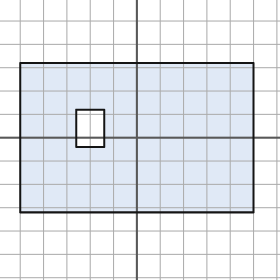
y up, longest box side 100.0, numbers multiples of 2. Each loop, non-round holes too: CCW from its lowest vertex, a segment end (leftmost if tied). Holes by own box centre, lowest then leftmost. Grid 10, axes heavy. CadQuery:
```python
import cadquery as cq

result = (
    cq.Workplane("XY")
    .moveTo(-50.0, -32.0)
    .lineTo(50.0, -32.0)
    .lineTo(50.0, 32.0)
    .lineTo(-50.0, 32.0)
    .close()
    .moveTo(-26.0, -4.0)
    .lineTo(-14.0, -4.0)
    .lineTo(-14.0, 12.0)
    .lineTo(-26.0, 12.0)
    .close()
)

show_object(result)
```